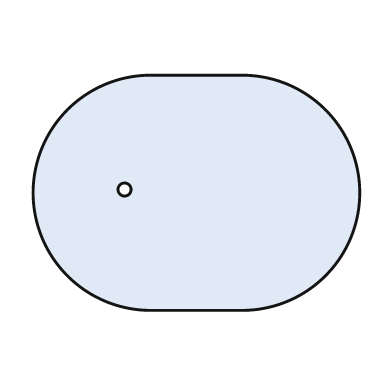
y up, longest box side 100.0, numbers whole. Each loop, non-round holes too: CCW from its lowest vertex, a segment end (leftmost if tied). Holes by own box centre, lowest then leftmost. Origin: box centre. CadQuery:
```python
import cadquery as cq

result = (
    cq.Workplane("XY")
    .moveTo(-14.0, -36.0)
    .lineTo(14.0, -36.0)
    .threePointArc((50.0, 0.0), (14.0, 36.0))
    .lineTo(-14.0, 36.0)
    .threePointArc((-50.0, 0.0), (-14.0, -36.0))
    .close()
    .moveTo(-22.0, 1.0)
    .circle(2.0)
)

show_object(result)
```